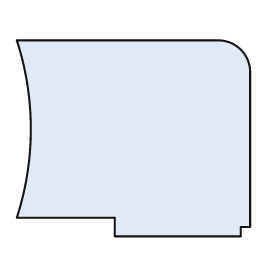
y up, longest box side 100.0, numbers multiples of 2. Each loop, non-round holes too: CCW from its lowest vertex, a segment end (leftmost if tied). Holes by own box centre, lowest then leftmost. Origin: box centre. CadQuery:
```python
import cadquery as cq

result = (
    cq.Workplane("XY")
    .moveTo(-8.0, -42.0)
    .lineTo(46.0, -42.0)
    .lineTo(46.0, -38.0)
    .lineTo(50.0, -38.0)
    .lineTo(50.0, 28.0)
    .threePointArc((46.0, 38.0), (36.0, 42.0))
    .lineTo(-50.0, 42.0)
    .threePointArc((-44.0, 4.0), (-50.0, -34.0))
    .lineTo(-8.0, -34.0)
    .close()
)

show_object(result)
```